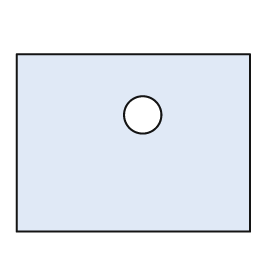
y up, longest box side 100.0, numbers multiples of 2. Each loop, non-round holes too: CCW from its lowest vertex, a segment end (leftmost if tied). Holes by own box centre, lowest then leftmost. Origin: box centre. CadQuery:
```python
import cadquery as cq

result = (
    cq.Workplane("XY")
    .moveTo(-50.0, -38.0)
    .lineTo(50.0, -38.0)
    .lineTo(50.0, 38.0)
    .lineTo(-50.0, 38.0)
    .close()
    .moveTo(4.0, 12.0)
    .circle(8.0)
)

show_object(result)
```